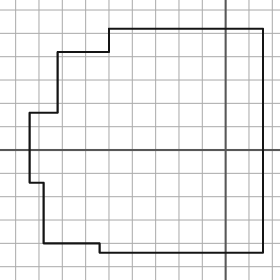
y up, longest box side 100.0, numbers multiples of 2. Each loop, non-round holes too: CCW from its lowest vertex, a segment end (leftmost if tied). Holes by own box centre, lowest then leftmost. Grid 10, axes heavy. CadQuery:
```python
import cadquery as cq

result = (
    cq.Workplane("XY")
    .moveTo(-54.0, -44.0)
    .lineTo(16.0, -44.0)
    .lineTo(16.0, 52.0)
    .lineTo(-50.0, 52.0)
    .lineTo(-50.0, 42.0)
    .lineTo(-72.0, 42.0)
    .lineTo(-72.0, 16.0)
    .lineTo(-84.0, 16.0)
    .lineTo(-84.0, -14.0)
    .lineTo(-78.0, -14.0)
    .lineTo(-78.0, -40.0)
    .lineTo(-54.0, -40.0)
    .close()
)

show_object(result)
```